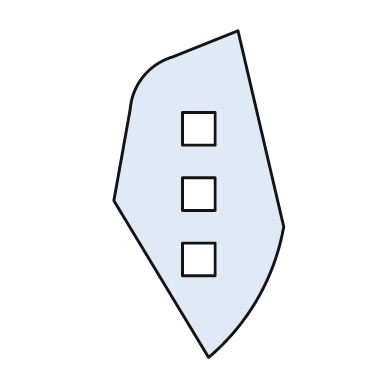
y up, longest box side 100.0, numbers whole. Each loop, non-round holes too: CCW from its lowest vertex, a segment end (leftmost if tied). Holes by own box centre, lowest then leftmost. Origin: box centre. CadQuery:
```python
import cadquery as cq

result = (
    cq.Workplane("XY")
    .moveTo(3.0, -50.0)
    .threePointArc((18.0, -32.0), (26.0, -10.0))
    .lineTo(12.0, 50.0)
    .lineTo(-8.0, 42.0)
    .threePointArc((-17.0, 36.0), (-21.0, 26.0))
    .lineTo(-26.0, -2.0)
    .close()
    .moveTo(-5.0, -25.0)
    .lineTo(5.0, -25.0)
    .lineTo(5.0, -15.0)
    .lineTo(-5.0, -15.0)
    .close()
    .moveTo(-5.0, -5.0)
    .lineTo(5.0, -5.0)
    .lineTo(5.0, 5.0)
    .lineTo(-5.0, 5.0)
    .close()
    .moveTo(-5.0, 15.0)
    .lineTo(5.0, 15.0)
    .lineTo(5.0, 25.0)
    .lineTo(-5.0, 25.0)
    .close()
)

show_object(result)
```